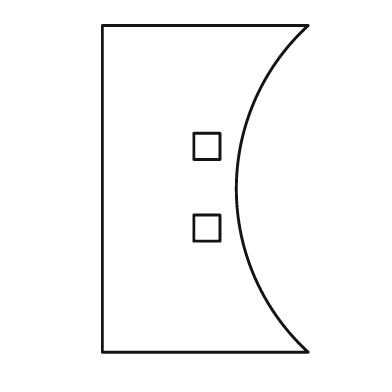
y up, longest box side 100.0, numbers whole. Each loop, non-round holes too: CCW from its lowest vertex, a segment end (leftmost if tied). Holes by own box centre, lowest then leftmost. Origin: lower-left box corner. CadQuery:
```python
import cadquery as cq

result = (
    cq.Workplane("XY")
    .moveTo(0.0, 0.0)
    .lineTo(63.0, 0.0)
    .threePointArc((41.0, 50.0), (63.0, 100.0))
    .lineTo(0.0, 100.0)
    .close()
    .moveTo(28.0, 34.0)
    .lineTo(36.0, 34.0)
    .lineTo(36.0, 42.0)
    .lineTo(28.0, 42.0)
    .close()
    .moveTo(28.0, 59.0)
    .lineTo(36.0, 59.0)
    .lineTo(36.0, 67.0)
    .lineTo(28.0, 67.0)
    .close()
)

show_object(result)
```